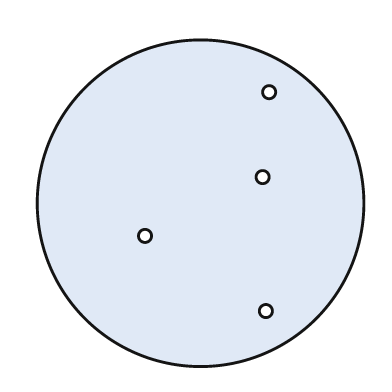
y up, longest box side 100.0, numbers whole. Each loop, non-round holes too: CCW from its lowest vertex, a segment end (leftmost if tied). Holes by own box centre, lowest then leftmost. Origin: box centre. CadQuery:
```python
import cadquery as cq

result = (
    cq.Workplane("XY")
    .moveTo(0.0, 0.0)
    .circle(50.0)
    .moveTo(20.0, -33.0)
    .circle(2.0)
    .moveTo(-17.0, -10.0)
    .circle(2.0)
    .moveTo(19.0, 8.0)
    .circle(2.0)
    .moveTo(21.0, 34.0)
    .circle(2.0)
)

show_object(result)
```